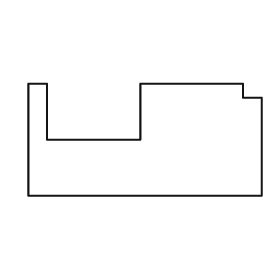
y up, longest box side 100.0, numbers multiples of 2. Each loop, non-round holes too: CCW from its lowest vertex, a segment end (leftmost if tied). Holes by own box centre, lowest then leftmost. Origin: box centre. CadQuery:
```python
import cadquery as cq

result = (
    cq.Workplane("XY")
    .moveTo(-50.0, -24.0)
    .lineTo(50.0, -24.0)
    .lineTo(50.0, 18.0)
    .lineTo(42.0, 18.0)
    .lineTo(42.0, 24.0)
    .lineTo(-2.0, 24.0)
    .lineTo(-2.0, 0.0)
    .lineTo(-42.0, 0.0)
    .lineTo(-42.0, 24.0)
    .lineTo(-50.0, 24.0)
    .close()
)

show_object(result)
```